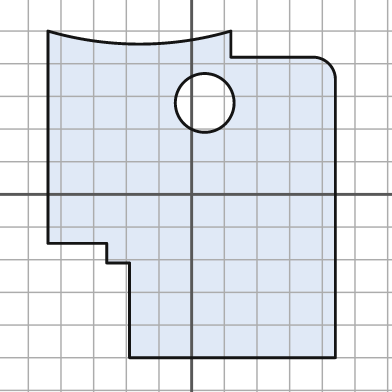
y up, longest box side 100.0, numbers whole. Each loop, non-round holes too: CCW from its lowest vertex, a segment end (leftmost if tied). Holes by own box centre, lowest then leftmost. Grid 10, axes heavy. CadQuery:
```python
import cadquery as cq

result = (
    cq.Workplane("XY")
    .moveTo(-19.0, -50.0)
    .lineTo(44.0, -50.0)
    .lineTo(44.0, 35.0)
    .threePointArc((42.0, 40.0), (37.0, 42.0))
    .lineTo(12.0, 42.0)
    .lineTo(12.0, 50.0)
    .threePointArc((-16.0, 46.0), (-44.0, 50.0))
    .lineTo(-44.0, -15.0)
    .lineTo(-26.0, -15.0)
    .lineTo(-26.0, -21.0)
    .lineTo(-19.0, -21.0)
    .close()
    .moveTo(4.0, 28.0)
    .circle(9.0)
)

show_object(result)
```